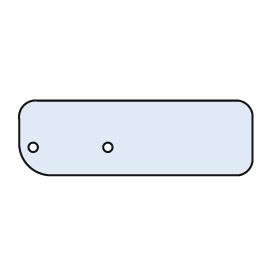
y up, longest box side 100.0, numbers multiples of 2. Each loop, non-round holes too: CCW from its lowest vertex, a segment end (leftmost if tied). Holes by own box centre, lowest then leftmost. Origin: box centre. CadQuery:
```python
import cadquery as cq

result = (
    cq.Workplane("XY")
    .moveTo(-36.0, -16.0)
    .lineTo(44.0, -16.0)
    .threePointArc((48.0, -14.0), (50.0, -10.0))
    .lineTo(50.0, 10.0)
    .threePointArc((48.0, 14.0), (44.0, 16.0))
    .lineTo(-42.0, 16.0)
    .threePointArc((-48.0, 14.0), (-50.0, 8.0))
    .lineTo(-50.0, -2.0)
    .threePointArc((-46.0, -12.0), (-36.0, -16.0))
    .close()
    .moveTo(-44.0, -4.0)
    .circle(2.0)
    .moveTo(-12.0, -4.0)
    .circle(2.0)
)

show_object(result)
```